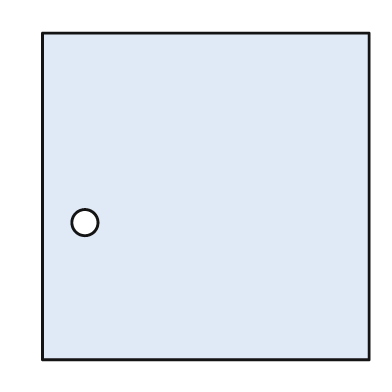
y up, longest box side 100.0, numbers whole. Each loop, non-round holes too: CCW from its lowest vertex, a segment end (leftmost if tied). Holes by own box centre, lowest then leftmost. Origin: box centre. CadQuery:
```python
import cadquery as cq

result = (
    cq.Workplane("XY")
    .moveTo(-50.0, -50.0)
    .lineTo(50.0, -50.0)
    .lineTo(50.0, 50.0)
    .lineTo(-50.0, 50.0)
    .close()
    .moveTo(-37.0, -8.0)
    .circle(4.0)
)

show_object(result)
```